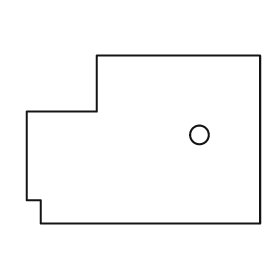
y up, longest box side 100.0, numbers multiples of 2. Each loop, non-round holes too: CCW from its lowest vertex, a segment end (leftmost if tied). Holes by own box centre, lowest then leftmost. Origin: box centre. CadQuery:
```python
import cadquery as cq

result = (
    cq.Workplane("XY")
    .moveTo(-44.0, -36.0)
    .lineTo(50.0, -36.0)
    .lineTo(50.0, 36.0)
    .lineTo(-20.0, 36.0)
    .lineTo(-20.0, 12.0)
    .lineTo(-50.0, 12.0)
    .lineTo(-50.0, -26.0)
    .lineTo(-44.0, -26.0)
    .close()
    .moveTo(24.0, 2.0)
    .circle(4.0)
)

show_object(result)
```